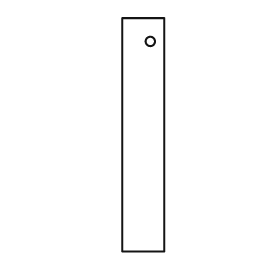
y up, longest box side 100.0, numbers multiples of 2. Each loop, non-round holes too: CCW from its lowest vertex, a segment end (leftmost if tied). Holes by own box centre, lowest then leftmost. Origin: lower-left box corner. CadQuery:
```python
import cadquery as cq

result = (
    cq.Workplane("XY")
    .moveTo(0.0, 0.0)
    .lineTo(18.0, 0.0)
    .lineTo(18.0, 100.0)
    .lineTo(0.0, 100.0)
    .close()
    .moveTo(12.0, 90.0)
    .circle(2.0)
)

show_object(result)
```